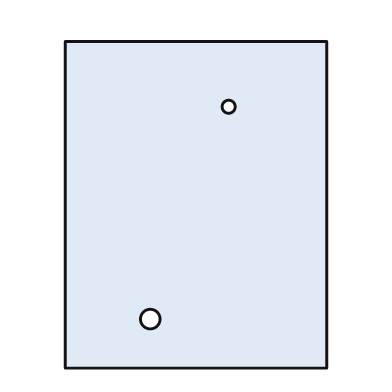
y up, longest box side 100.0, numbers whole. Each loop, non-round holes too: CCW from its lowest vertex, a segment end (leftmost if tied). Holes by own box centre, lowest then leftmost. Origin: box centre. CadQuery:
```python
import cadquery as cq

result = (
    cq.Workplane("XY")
    .moveTo(-40.0, -50.0)
    .lineTo(40.0, -50.0)
    .lineTo(40.0, 50.0)
    .lineTo(-40.0, 50.0)
    .close()
    .moveTo(-14.0, -35.0)
    .circle(3.0)
    .moveTo(10.0, 30.0)
    .circle(2.0)
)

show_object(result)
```